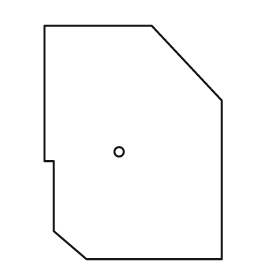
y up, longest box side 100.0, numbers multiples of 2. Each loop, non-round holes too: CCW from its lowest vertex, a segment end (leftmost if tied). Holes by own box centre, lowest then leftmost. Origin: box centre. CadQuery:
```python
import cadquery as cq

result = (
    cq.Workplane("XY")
    .moveTo(-20.0, -50.0)
    .lineTo(38.0, -50.0)
    .lineTo(38.0, 18.0)
    .lineTo(8.0, 50.0)
    .lineTo(-38.0, 50.0)
    .lineTo(-38.0, -8.0)
    .lineTo(-34.0, -8.0)
    .lineTo(-34.0, -38.0)
    .close()
    .moveTo(-6.0, -4.0)
    .circle(2.0)
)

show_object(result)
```